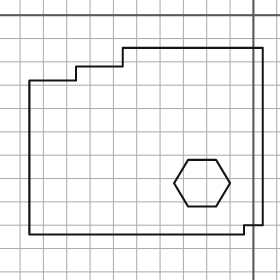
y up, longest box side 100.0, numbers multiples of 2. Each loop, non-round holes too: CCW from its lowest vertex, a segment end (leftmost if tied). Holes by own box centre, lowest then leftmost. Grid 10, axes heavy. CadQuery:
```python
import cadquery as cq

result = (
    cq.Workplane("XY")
    .moveTo(-96.0, -94.0)
    .lineTo(-4.0, -94.0)
    .lineTo(-4.0, -90.0)
    .lineTo(4.0, -90.0)
    .lineTo(4.0, -14.0)
    .lineTo(-56.0, -14.0)
    .lineTo(-56.0, -22.0)
    .lineTo(-76.0, -22.0)
    .lineTo(-76.0, -28.0)
    .lineTo(-96.0, -28.0)
    .close()
    .moveTo(-28.0, -82.0)
    .lineTo(-16.0, -82.0)
    .lineTo(-10.0, -72.0)
    .lineTo(-16.0, -62.0)
    .lineTo(-28.0, -62.0)
    .lineTo(-34.0, -72.0)
    .close()
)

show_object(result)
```